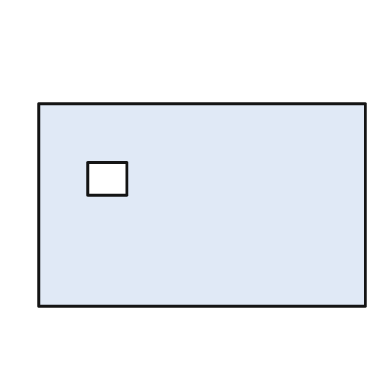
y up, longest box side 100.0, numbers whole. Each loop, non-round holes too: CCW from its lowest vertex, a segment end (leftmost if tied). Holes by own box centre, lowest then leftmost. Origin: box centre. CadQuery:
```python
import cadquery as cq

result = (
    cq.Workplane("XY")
    .moveTo(-50.0, -31.0)
    .lineTo(50.0, -31.0)
    .lineTo(50.0, 31.0)
    .lineTo(-50.0, 31.0)
    .close()
    .moveTo(-35.0, 3.0)
    .lineTo(-23.0, 3.0)
    .lineTo(-23.0, 13.0)
    .lineTo(-35.0, 13.0)
    .close()
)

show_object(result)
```